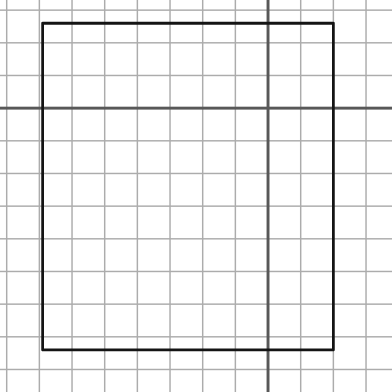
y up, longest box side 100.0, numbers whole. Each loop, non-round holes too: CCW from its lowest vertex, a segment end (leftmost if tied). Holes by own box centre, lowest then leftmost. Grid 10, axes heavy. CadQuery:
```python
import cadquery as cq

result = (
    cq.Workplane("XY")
    .moveTo(-69.0, -74.0)
    .lineTo(20.0, -74.0)
    .lineTo(20.0, 26.0)
    .lineTo(-69.0, 26.0)
    .close()
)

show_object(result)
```